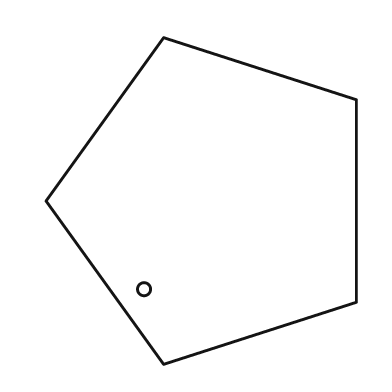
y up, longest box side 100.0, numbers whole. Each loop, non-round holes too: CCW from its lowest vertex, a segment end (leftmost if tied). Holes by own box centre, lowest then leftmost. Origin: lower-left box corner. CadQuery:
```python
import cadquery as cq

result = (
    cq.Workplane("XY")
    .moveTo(36.0, 0.0)
    .lineTo(95.0, 19.0)
    .lineTo(95.0, 81.0)
    .lineTo(36.0, 100.0)
    .lineTo(0.0, 50.0)
    .close()
    .moveTo(30.0, 23.0)
    .circle(2.0)
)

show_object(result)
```